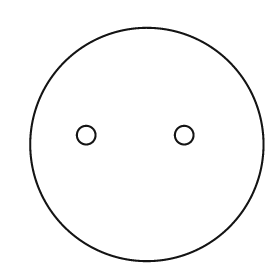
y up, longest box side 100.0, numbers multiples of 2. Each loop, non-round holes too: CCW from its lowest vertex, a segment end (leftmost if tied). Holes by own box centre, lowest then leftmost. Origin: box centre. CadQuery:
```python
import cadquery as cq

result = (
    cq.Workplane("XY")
    .moveTo(0.0, 0.0)
    .circle(50.0)
    .moveTo(-26.0, 4.0)
    .circle(4.0)
    .moveTo(16.0, 4.0)
    .circle(4.0)
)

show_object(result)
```